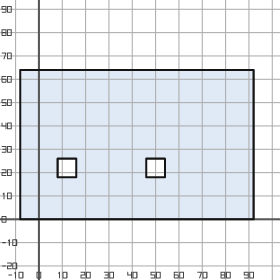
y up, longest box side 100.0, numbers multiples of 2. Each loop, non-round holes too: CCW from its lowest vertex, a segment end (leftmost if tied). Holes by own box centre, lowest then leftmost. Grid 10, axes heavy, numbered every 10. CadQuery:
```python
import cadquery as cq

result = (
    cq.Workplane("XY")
    .moveTo(-8.0, 0.0)
    .lineTo(92.0, 0.0)
    .lineTo(92.0, 64.0)
    .lineTo(-8.0, 64.0)
    .close()
    .moveTo(8.0, 18.0)
    .lineTo(16.0, 18.0)
    .lineTo(16.0, 26.0)
    .lineTo(8.0, 26.0)
    .close()
    .moveTo(46.0, 18.0)
    .lineTo(54.0, 18.0)
    .lineTo(54.0, 26.0)
    .lineTo(46.0, 26.0)
    .close()
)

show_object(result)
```